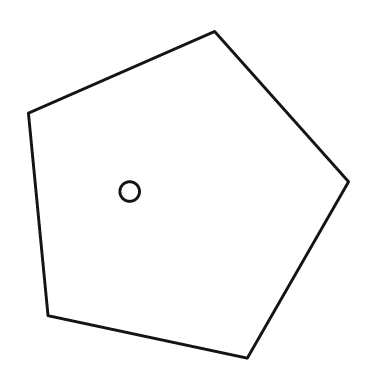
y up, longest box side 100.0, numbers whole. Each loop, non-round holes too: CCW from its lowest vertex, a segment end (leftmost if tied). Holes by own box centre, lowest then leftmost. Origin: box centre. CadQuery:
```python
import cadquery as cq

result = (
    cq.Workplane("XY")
    .moveTo(18.0, -50.0)
    .lineTo(49.0, 4.0)
    .lineTo(8.0, 50.0)
    .lineTo(-49.0, 25.0)
    .lineTo(-43.0, -37.0)
    .close()
    .moveTo(-18.0, 1.0)
    .circle(3.0)
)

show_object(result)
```